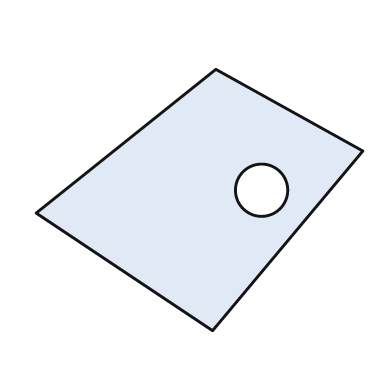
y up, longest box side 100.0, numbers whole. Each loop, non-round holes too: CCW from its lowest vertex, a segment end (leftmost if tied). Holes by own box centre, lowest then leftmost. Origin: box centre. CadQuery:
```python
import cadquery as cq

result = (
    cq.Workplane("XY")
    .moveTo(4.0, -40.0)
    .lineTo(50.0, 15.0)
    .lineTo(5.0, 40.0)
    .lineTo(-50.0, -4.0)
    .close()
    .moveTo(19.0, 3.0)
    .circle(8.0)
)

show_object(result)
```